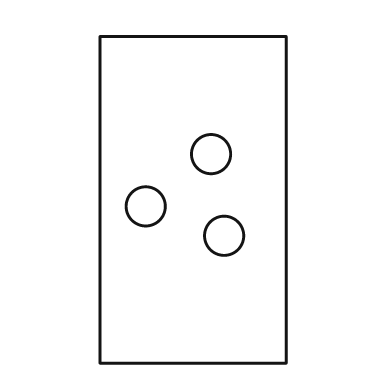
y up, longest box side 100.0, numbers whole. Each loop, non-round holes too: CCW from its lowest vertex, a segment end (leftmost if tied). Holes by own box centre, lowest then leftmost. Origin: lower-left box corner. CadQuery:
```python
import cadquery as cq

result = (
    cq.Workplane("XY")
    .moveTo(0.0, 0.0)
    .lineTo(57.0, 0.0)
    .lineTo(57.0, 100.0)
    .lineTo(0.0, 100.0)
    .close()
    .moveTo(38.0, 39.0)
    .circle(6.0)
    .moveTo(14.0, 48.0)
    .circle(6.0)
    .moveTo(34.0, 64.0)
    .circle(6.0)
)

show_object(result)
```